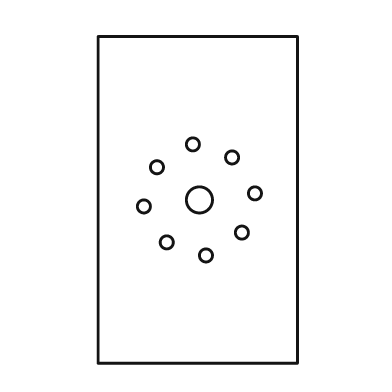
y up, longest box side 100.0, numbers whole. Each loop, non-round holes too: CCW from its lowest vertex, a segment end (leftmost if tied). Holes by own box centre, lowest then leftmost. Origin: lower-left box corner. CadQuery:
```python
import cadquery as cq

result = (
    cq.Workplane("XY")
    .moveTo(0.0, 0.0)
    .lineTo(61.0, 0.0)
    .lineTo(61.0, 100.0)
    .lineTo(0.0, 100.0)
    .close()
    .moveTo(33.0, 33.0)
    .circle(2.0)
    .moveTo(21.0, 37.0)
    .circle(2.0)
    .moveTo(44.0, 40.0)
    .circle(2.0)
    .moveTo(14.0, 48.0)
    .circle(2.0)
    .moveTo(31.0, 50.0)
    .circle(4.0)
    .moveTo(48.0, 52.0)
    .circle(2.0)
    .moveTo(18.0, 60.0)
    .circle(2.0)
    .moveTo(41.0, 63.0)
    .circle(2.0)
    .moveTo(29.0, 67.0)
    .circle(2.0)
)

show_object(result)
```